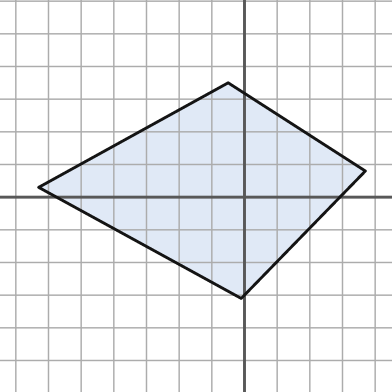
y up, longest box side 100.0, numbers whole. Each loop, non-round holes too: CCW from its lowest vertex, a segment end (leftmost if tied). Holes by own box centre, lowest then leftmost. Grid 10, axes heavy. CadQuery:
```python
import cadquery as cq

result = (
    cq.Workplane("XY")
    .moveTo(-1.0, -31.0)
    .lineTo(37.0, 8.0)
    .lineTo(-5.0, 35.0)
    .lineTo(-63.0, 3.0)
    .close()
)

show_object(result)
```